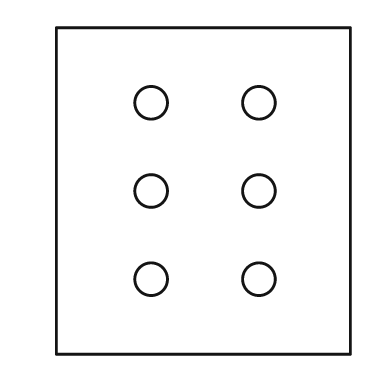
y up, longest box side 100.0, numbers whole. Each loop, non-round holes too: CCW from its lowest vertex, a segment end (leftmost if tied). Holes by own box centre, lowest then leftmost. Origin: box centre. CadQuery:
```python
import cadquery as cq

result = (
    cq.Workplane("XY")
    .moveTo(-45.0, -50.0)
    .lineTo(45.0, -50.0)
    .lineTo(45.0, 50.0)
    .lineTo(-45.0, 50.0)
    .close()
    .moveTo(-16.0, -27.0)
    .circle(5.0)
    .moveTo(17.0, -27.0)
    .circle(5.0)
    .moveTo(-16.0, 0.0)
    .circle(5.0)
    .moveTo(17.0, 0.0)
    .circle(5.0)
    .moveTo(-16.0, 27.0)
    .circle(5.0)
    .moveTo(17.0, 27.0)
    .circle(5.0)
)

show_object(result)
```